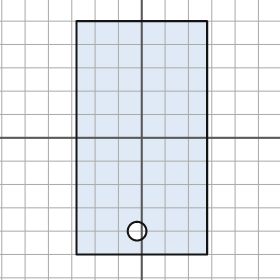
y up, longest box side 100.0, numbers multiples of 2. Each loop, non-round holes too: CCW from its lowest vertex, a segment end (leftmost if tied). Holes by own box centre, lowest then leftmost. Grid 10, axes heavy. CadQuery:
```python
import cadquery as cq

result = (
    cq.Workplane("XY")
    .moveTo(-28.0, -50.0)
    .lineTo(28.0, -50.0)
    .lineTo(28.0, 50.0)
    .lineTo(-28.0, 50.0)
    .close()
    .moveTo(-2.0, -40.0)
    .circle(4.0)
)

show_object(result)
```